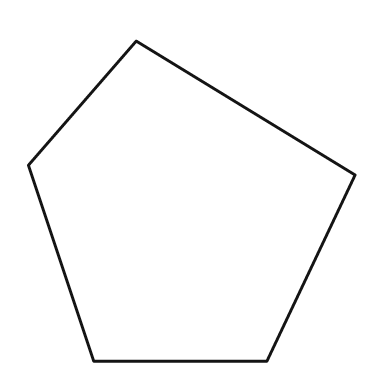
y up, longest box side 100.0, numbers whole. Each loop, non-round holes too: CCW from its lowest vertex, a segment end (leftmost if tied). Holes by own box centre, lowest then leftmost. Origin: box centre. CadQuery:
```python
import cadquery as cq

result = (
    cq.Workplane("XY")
    .moveTo(-30.0, -49.0)
    .lineTo(23.0, -49.0)
    .lineTo(50.0, 8.0)
    .lineTo(-17.0, 49.0)
    .lineTo(-50.0, 11.0)
    .close()
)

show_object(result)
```